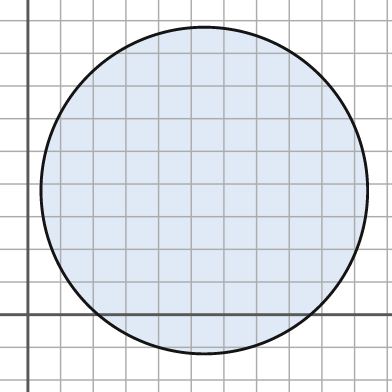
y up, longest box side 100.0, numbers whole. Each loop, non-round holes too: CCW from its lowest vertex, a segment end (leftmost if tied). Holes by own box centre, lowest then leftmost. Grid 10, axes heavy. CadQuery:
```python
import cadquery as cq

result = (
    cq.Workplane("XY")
    .moveTo(54.0, 38.0)
    .circle(50.0)
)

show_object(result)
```